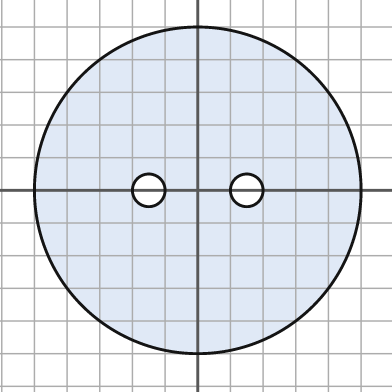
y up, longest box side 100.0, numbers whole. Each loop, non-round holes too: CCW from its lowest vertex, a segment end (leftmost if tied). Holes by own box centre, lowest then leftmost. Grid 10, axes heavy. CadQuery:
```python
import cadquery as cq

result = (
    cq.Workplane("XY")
    .moveTo(0.0, 0.0)
    .circle(50.0)
    .moveTo(-15.0, 0.0)
    .circle(5.0)
    .moveTo(15.0, 0.0)
    .circle(5.0)
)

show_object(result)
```